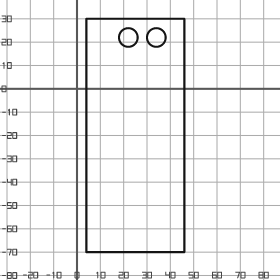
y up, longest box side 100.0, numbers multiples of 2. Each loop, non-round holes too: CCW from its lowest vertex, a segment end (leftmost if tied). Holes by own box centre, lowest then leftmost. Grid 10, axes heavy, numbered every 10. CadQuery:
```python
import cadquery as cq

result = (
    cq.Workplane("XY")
    .moveTo(4.0, -70.0)
    .lineTo(46.0, -70.0)
    .lineTo(46.0, 30.0)
    .lineTo(4.0, 30.0)
    .close()
    .moveTo(22.0, 22.0)
    .circle(4.0)
    .moveTo(34.0, 22.0)
    .circle(4.0)
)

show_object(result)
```